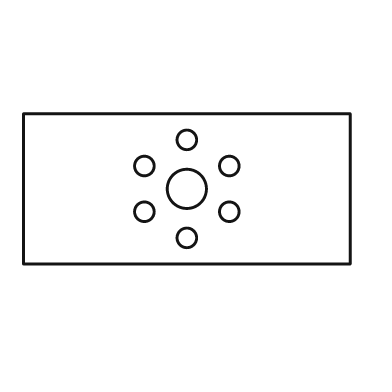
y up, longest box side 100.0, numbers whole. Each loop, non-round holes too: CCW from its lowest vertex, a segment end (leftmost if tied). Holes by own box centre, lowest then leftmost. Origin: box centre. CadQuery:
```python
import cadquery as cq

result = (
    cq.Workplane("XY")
    .moveTo(-50.0, -23.0)
    .lineTo(50.0, -23.0)
    .lineTo(50.0, 23.0)
    .lineTo(-50.0, 23.0)
    .close()
    .moveTo(0.0, -15.0)
    .circle(3.0)
    .moveTo(-13.0, -7.0)
    .circle(3.0)
    .moveTo(13.0, -7.0)
    .circle(3.0)
    .moveTo(0.0, 0.0)
    .circle(6.0)
    .moveTo(-13.0, 7.0)
    .circle(3.0)
    .moveTo(13.0, 7.0)
    .circle(3.0)
    .moveTo(0.0, 15.0)
    .circle(3.0)
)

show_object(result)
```